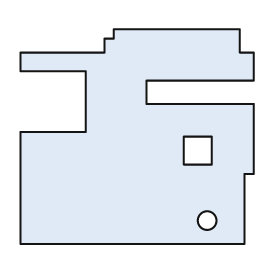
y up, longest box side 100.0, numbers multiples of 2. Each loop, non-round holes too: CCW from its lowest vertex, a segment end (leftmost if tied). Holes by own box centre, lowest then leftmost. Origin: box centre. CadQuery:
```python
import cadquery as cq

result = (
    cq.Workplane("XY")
    .moveTo(-50.0, -46.0)
    .lineTo(46.0, -46.0)
    .lineTo(46.0, -16.0)
    .lineTo(50.0, -16.0)
    .lineTo(50.0, 14.0)
    .lineTo(4.0, 14.0)
    .lineTo(4.0, 24.0)
    .lineTo(50.0, 24.0)
    .lineTo(50.0, 36.0)
    .lineTo(44.0, 36.0)
    .lineTo(44.0, 46.0)
    .lineTo(-10.0, 46.0)
    .lineTo(-10.0, 42.0)
    .lineTo(-14.0, 42.0)
    .lineTo(-14.0, 36.0)
    .lineTo(-50.0, 36.0)
    .lineTo(-50.0, 28.0)
    .lineTo(-22.0, 28.0)
    .lineTo(-22.0, 2.0)
    .lineTo(-50.0, 2.0)
    .close()
    .moveTo(30.0, -36.0)
    .circle(4.0)
    .moveTo(20.0, -12.0)
    .lineTo(32.0, -12.0)
    .lineTo(32.0, 0.0)
    .lineTo(20.0, 0.0)
    .close()
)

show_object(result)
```